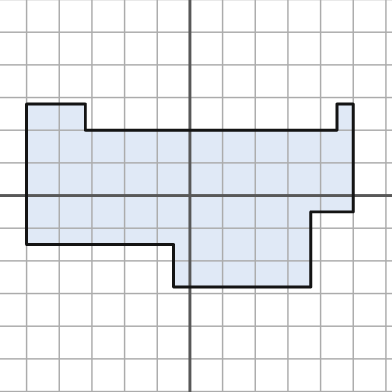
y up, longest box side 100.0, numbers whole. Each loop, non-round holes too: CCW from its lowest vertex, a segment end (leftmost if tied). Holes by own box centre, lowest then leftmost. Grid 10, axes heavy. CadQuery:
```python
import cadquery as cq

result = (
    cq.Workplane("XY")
    .moveTo(-5.0, -28.0)
    .lineTo(37.0, -28.0)
    .lineTo(37.0, -5.0)
    .lineTo(50.0, -5.0)
    .lineTo(50.0, 28.0)
    .lineTo(45.0, 28.0)
    .lineTo(45.0, 20.0)
    .lineTo(-32.0, 20.0)
    .lineTo(-32.0, 28.0)
    .lineTo(-50.0, 28.0)
    .lineTo(-50.0, -15.0)
    .lineTo(-5.0, -15.0)
    .close()
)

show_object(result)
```